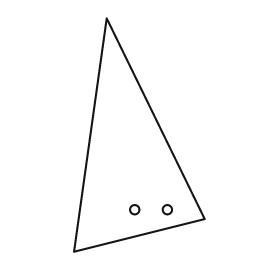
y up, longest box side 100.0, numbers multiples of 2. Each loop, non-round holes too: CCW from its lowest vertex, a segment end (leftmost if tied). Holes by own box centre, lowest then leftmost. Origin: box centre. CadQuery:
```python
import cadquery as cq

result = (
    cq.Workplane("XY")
    .moveTo(-28.0, -50.0)
    .lineTo(28.0, -36.0)
    .lineTo(-14.0, 50.0)
    .close()
    .moveTo(-2.0, -32.0)
    .circle(2.0)
    .moveTo(12.0, -32.0)
    .circle(2.0)
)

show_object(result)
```